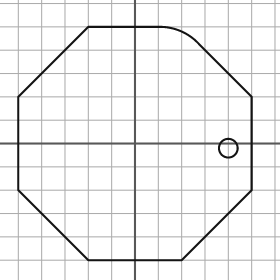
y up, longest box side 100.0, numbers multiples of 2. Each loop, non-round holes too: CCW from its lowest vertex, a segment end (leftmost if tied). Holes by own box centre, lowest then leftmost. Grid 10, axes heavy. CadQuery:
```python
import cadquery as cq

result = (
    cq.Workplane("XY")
    .moveTo(-20.0, -50.0)
    .lineTo(20.0, -50.0)
    .lineTo(50.0, -20.0)
    .lineTo(50.0, 20.0)
    .lineTo(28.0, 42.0)
    .threePointArc((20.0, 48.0), (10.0, 50.0))
    .lineTo(-20.0, 50.0)
    .lineTo(-50.0, 20.0)
    .lineTo(-50.0, -20.0)
    .close()
    .moveTo(40.0, -2.0)
    .circle(4.0)
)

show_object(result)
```